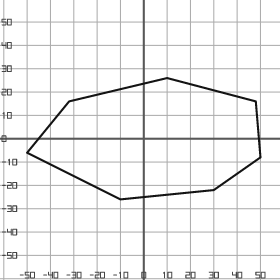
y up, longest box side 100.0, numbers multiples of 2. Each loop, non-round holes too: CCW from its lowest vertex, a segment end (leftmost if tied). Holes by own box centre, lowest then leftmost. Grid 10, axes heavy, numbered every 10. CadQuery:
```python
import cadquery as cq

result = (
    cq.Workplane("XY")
    .moveTo(-10.0, -26.0)
    .lineTo(30.0, -22.0)
    .lineTo(50.0, -8.0)
    .lineTo(48.0, 16.0)
    .lineTo(10.0, 26.0)
    .lineTo(-32.0, 16.0)
    .lineTo(-50.0, -6.0)
    .close()
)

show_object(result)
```